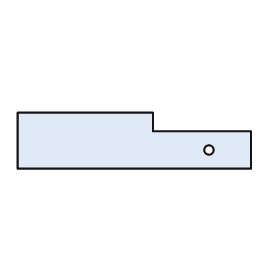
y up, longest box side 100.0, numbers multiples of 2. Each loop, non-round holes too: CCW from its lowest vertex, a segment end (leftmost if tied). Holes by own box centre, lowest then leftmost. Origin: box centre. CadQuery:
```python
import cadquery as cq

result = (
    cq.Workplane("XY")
    .moveTo(-50.0, -12.0)
    .lineTo(50.0, -12.0)
    .lineTo(50.0, 4.0)
    .lineTo(8.0, 4.0)
    .lineTo(8.0, 12.0)
    .lineTo(-50.0, 12.0)
    .close()
    .moveTo(32.0, -4.0)
    .circle(2.0)
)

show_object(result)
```